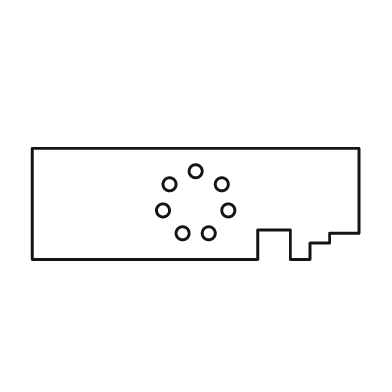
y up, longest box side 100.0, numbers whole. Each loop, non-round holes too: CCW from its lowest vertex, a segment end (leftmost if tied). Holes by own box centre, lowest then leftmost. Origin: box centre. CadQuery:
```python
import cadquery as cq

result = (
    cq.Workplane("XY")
    .moveTo(-50.0, -17.0)
    .lineTo(19.0, -17.0)
    .lineTo(19.0, -8.0)
    .lineTo(29.0, -8.0)
    .lineTo(29.0, -17.0)
    .lineTo(35.0, -17.0)
    .lineTo(35.0, -12.0)
    .lineTo(41.0, -12.0)
    .lineTo(41.0, -9.0)
    .lineTo(50.0, -9.0)
    .lineTo(50.0, 17.0)
    .lineTo(-50.0, 17.0)
    .close()
    .moveTo(-4.0, -9.0)
    .circle(2.0)
    .moveTo(4.0, -9.0)
    .circle(2.0)
    .moveTo(-10.0, -2.0)
    .circle(2.0)
    .moveTo(10.0, -2.0)
    .circle(2.0)
    .moveTo(-8.0, 6.0)
    .circle(2.0)
    .moveTo(8.0, 6.0)
    .circle(2.0)
    .moveTo(0.0, 10.0)
    .circle(2.0)
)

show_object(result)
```